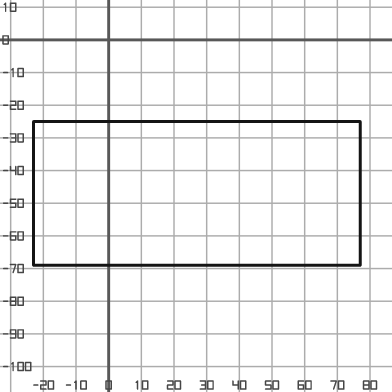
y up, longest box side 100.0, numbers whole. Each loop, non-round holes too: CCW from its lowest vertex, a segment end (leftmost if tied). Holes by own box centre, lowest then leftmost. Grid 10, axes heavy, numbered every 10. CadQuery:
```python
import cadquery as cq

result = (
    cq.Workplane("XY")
    .moveTo(-23.0, -69.0)
    .lineTo(77.0, -69.0)
    .lineTo(77.0, -25.0)
    .lineTo(-23.0, -25.0)
    .close()
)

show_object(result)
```